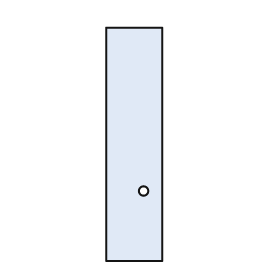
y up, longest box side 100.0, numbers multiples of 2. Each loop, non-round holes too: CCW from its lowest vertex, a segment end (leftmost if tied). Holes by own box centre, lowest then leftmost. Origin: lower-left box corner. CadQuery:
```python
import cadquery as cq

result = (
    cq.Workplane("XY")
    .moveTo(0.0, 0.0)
    .lineTo(24.0, 0.0)
    .lineTo(24.0, 100.0)
    .lineTo(0.0, 100.0)
    .close()
    .moveTo(16.0, 30.0)
    .circle(2.0)
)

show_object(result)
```